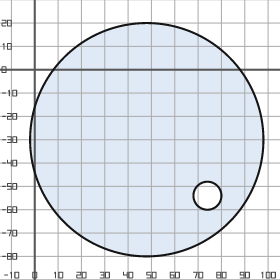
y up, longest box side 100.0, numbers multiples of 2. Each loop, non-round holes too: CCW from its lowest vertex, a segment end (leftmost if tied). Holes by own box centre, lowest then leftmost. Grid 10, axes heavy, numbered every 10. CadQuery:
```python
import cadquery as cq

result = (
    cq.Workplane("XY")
    .moveTo(48.0, -30.0)
    .circle(50.0)
    .moveTo(74.0, -54.0)
    .circle(6.0)
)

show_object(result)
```